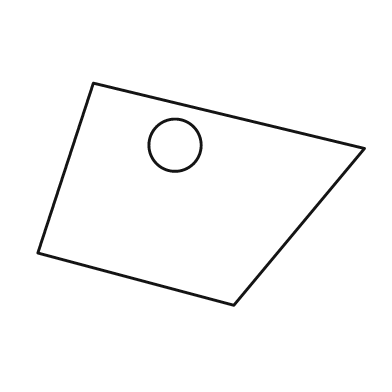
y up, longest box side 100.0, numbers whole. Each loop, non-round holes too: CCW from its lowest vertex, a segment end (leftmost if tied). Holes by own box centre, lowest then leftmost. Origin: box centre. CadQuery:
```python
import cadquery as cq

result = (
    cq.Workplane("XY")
    .moveTo(10.0, -34.0)
    .lineTo(50.0, 14.0)
    .lineTo(-33.0, 34.0)
    .lineTo(-50.0, -18.0)
    .close()
    .moveTo(-8.0, 15.0)
    .circle(8.0)
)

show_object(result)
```